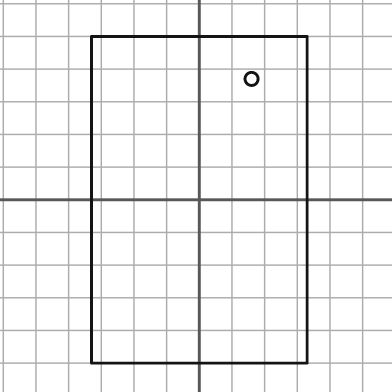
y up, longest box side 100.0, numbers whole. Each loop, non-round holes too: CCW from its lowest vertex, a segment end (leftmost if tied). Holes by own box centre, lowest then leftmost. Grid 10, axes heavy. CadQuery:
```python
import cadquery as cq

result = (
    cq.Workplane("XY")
    .moveTo(-33.0, -50.0)
    .lineTo(33.0, -50.0)
    .lineTo(33.0, 50.0)
    .lineTo(-33.0, 50.0)
    .close()
    .moveTo(16.0, 37.0)
    .circle(2.0)
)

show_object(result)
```